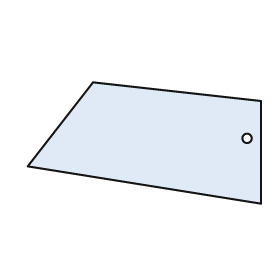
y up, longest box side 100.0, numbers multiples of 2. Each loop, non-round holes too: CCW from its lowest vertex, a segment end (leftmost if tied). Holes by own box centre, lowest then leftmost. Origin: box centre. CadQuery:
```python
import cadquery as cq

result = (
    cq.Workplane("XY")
    .moveTo(50.0, -26.0)
    .lineTo(50.0, 18.0)
    .lineTo(-22.0, 26.0)
    .lineTo(-50.0, -10.0)
    .close()
    .moveTo(44.0, 2.0)
    .circle(2.0)
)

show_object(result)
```